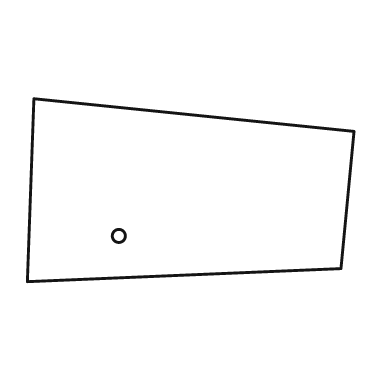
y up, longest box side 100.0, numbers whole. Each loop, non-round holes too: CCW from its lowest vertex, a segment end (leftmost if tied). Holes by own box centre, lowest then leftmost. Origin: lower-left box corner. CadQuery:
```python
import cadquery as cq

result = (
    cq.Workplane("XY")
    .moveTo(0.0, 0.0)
    .lineTo(96.0, 4.0)
    .lineTo(100.0, 46.0)
    .lineTo(2.0, 56.0)
    .close()
    .moveTo(28.0, 14.0)
    .circle(2.0)
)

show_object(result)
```